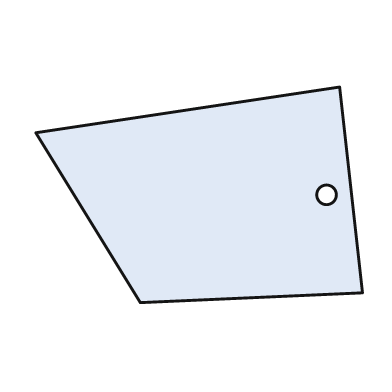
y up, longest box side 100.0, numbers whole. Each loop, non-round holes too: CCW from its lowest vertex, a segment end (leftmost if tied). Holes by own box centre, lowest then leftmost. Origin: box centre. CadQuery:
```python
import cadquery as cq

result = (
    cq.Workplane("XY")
    .moveTo(-18.0, -33.0)
    .lineTo(50.0, -30.0)
    .lineTo(43.0, 33.0)
    .lineTo(-50.0, 19.0)
    .close()
    .moveTo(39.0, 0.0)
    .circle(3.0)
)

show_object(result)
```